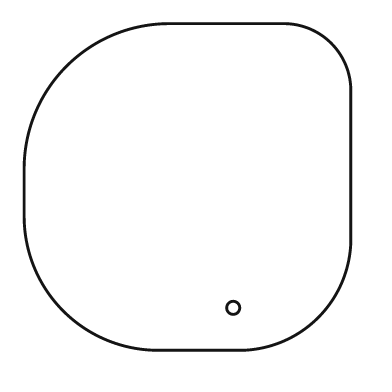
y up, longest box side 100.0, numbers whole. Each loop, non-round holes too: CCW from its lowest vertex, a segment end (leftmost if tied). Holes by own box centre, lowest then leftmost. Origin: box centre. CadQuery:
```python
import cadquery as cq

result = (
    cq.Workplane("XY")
    .moveTo(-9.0, -50.0)
    .lineTo(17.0, -50.0)
    .threePointArc((40.0, -40.0), (50.0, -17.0))
    .lineTo(50.0, 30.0)
    .threePointArc((44.0, 44.0), (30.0, 50.0))
    .lineTo(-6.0, 50.0)
    .threePointArc((-37.0, 37.0), (-50.0, 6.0))
    .lineTo(-50.0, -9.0)
    .threePointArc((-38.0, -38.0), (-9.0, -50.0))
    .close()
    .moveTo(14.0, -37.0)
    .circle(2.0)
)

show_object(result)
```